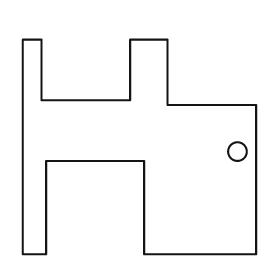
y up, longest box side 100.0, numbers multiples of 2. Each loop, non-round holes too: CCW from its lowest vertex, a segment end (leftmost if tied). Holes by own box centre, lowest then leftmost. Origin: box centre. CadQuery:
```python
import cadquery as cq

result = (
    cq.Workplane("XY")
    .moveTo(-50.0, -46.0)
    .lineTo(-40.0, -46.0)
    .lineTo(-40.0, -6.0)
    .lineTo(2.0, -6.0)
    .lineTo(2.0, -46.0)
    .lineTo(50.0, -46.0)
    .lineTo(50.0, 18.0)
    .lineTo(12.0, 18.0)
    .lineTo(12.0, 46.0)
    .lineTo(-4.0, 46.0)
    .lineTo(-4.0, 20.0)
    .lineTo(-42.0, 20.0)
    .lineTo(-42.0, 46.0)
    .lineTo(-50.0, 46.0)
    .close()
    .moveTo(42.0, -2.0)
    .circle(4.0)
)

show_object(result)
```